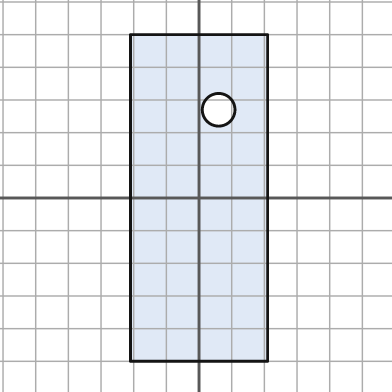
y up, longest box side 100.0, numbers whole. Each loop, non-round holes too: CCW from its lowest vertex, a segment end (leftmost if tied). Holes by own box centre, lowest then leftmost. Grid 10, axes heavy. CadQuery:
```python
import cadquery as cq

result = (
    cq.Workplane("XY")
    .moveTo(-21.0, -50.0)
    .lineTo(21.0, -50.0)
    .lineTo(21.0, 50.0)
    .lineTo(-21.0, 50.0)
    .close()
    .moveTo(6.0, 27.0)
    .circle(5.0)
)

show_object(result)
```